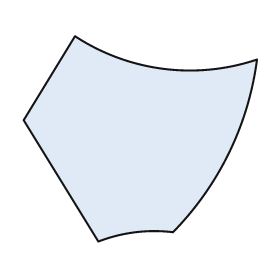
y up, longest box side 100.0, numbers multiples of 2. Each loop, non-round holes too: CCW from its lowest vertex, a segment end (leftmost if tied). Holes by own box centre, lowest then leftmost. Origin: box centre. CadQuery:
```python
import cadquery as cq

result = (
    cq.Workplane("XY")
    .moveTo(-18.0, -44.0)
    .threePointArc((-2.0, -40.0), (14.0, -40.0))
    .threePointArc((38.0, -6.0), (50.0, 34.0))
    .threePointArc((10.0, 30.0), (-28.0, 44.0))
    .lineTo(-50.0, 8.0)
    .close()
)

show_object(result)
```